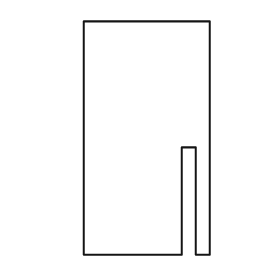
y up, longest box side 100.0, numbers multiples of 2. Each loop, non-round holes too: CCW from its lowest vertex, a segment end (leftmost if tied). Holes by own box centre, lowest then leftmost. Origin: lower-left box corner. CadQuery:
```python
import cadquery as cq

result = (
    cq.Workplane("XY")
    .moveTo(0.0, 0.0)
    .lineTo(42.0, 0.0)
    .lineTo(42.0, 46.0)
    .lineTo(48.0, 46.0)
    .lineTo(48.0, 0.0)
    .lineTo(54.0, 0.0)
    .lineTo(54.0, 100.0)
    .lineTo(0.0, 100.0)
    .close()
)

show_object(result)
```